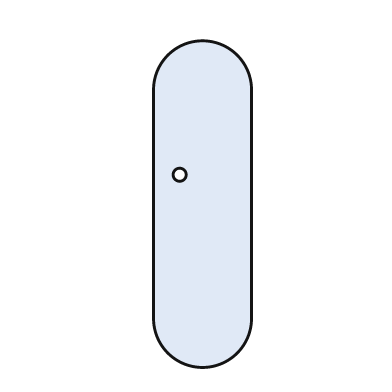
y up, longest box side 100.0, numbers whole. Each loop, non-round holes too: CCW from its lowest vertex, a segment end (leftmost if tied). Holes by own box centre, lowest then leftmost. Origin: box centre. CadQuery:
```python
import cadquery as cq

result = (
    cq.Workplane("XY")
    .moveTo(-15.0, -35.0)
    .threePointArc((0.0, -50.0), (15.0, -35.0))
    .lineTo(15.0, 35.0)
    .threePointArc((0.0, 50.0), (-15.0, 35.0))
    .close()
    .moveTo(-7.0, 9.0)
    .circle(2.0)
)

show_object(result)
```